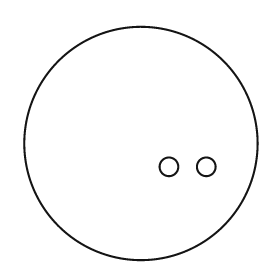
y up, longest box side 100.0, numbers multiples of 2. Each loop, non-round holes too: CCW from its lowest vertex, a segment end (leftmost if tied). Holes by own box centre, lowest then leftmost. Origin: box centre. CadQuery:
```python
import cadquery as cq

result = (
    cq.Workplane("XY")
    .moveTo(0.0, 0.0)
    .circle(50.0)
    .moveTo(12.0, -10.0)
    .circle(4.0)
    .moveTo(28.0, -10.0)
    .circle(4.0)
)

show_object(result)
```